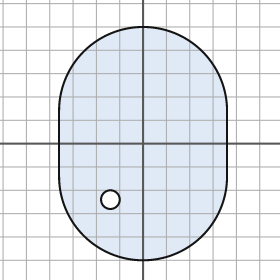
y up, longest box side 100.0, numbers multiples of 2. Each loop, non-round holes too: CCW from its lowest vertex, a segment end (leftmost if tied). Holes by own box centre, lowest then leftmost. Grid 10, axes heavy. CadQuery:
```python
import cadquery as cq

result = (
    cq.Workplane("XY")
    .moveTo(-36.0, -14.0)
    .threePointArc((0.0, -50.0), (36.0, -14.0))
    .lineTo(36.0, 14.0)
    .threePointArc((0.0, 50.0), (-36.0, 14.0))
    .close()
    .moveTo(-14.0, -24.0)
    .circle(4.0)
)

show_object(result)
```